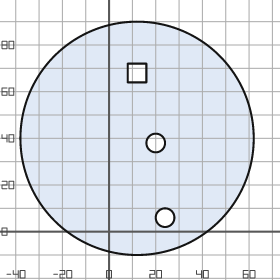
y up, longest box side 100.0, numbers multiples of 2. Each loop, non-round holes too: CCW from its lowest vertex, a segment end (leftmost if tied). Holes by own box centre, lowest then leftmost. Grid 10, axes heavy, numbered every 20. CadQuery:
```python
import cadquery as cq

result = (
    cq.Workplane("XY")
    .moveTo(12.0, 40.0)
    .circle(50.0)
    .moveTo(24.0, 6.0)
    .circle(4.0)
    .moveTo(20.0, 38.0)
    .circle(4.0)
    .moveTo(8.0, 64.0)
    .lineTo(16.0, 64.0)
    .lineTo(16.0, 72.0)
    .lineTo(8.0, 72.0)
    .close()
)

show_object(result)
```